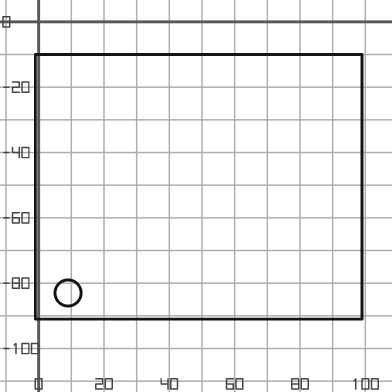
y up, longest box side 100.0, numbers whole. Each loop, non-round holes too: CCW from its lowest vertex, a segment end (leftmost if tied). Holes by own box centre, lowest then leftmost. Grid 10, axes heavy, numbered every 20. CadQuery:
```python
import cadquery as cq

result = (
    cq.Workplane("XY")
    .moveTo(-1.0, -91.0)
    .lineTo(99.0, -91.0)
    .lineTo(99.0, -10.0)
    .lineTo(-1.0, -10.0)
    .close()
    .moveTo(9.0, -83.0)
    .circle(4.0)
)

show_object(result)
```